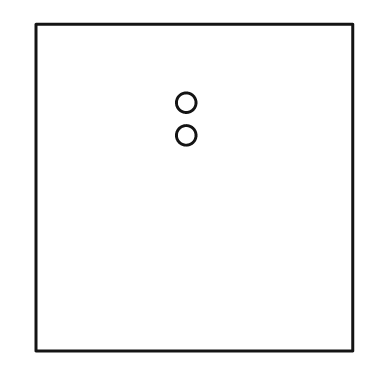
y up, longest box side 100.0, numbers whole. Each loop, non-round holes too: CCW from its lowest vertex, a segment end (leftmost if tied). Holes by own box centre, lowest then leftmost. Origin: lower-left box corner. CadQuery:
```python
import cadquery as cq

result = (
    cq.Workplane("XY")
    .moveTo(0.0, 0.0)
    .lineTo(97.0, 0.0)
    .lineTo(97.0, 100.0)
    .lineTo(0.0, 100.0)
    .close()
    .moveTo(46.0, 66.0)
    .circle(3.0)
    .moveTo(46.0, 76.0)
    .circle(3.0)
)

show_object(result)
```